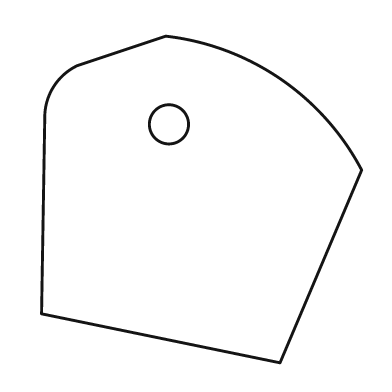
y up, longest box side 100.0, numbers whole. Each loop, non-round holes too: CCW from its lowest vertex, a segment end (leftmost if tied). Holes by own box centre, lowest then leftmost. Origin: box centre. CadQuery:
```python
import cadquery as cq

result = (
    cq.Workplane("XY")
    .moveTo(24.0, -50.0)
    .lineTo(49.0, 9.0)
    .threePointArc((24.0, 37.0), (-11.0, 50.0))
    .lineTo(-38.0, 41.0)
    .threePointArc((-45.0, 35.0), (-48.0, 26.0))
    .lineTo(-49.0, -35.0)
    .close()
    .moveTo(-10.0, 23.0)
    .circle(6.0)
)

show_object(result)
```